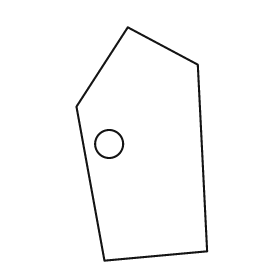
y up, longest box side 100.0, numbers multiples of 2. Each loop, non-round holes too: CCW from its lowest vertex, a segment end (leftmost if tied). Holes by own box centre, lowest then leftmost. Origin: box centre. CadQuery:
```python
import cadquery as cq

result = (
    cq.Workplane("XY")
    .moveTo(-16.0, -50.0)
    .lineTo(28.0, -46.0)
    .lineTo(24.0, 34.0)
    .lineTo(-6.0, 50.0)
    .lineTo(-28.0, 16.0)
    .close()
    .moveTo(-14.0, 0.0)
    .circle(6.0)
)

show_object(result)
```